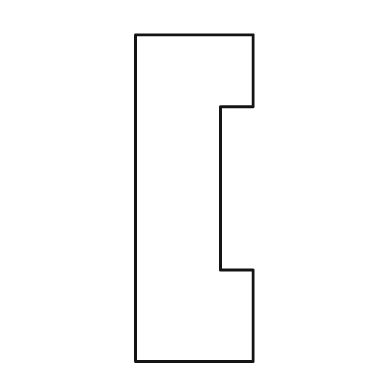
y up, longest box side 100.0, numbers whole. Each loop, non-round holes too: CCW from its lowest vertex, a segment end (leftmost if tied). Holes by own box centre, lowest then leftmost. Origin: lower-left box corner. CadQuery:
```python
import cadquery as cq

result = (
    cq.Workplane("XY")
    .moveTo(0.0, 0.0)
    .lineTo(36.0, 0.0)
    .lineTo(36.0, 28.0)
    .lineTo(26.0, 28.0)
    .lineTo(26.0, 78.0)
    .lineTo(36.0, 78.0)
    .lineTo(36.0, 100.0)
    .lineTo(0.0, 100.0)
    .close()
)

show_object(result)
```